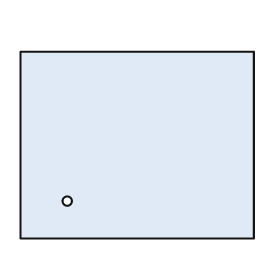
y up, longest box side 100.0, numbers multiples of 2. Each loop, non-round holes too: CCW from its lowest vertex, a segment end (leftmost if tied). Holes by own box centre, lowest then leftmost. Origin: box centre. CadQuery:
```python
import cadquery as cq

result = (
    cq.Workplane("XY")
    .moveTo(-50.0, -40.0)
    .lineTo(50.0, -40.0)
    .lineTo(50.0, 40.0)
    .lineTo(-50.0, 40.0)
    .close()
    .moveTo(-30.0, -24.0)
    .circle(2.0)
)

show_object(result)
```